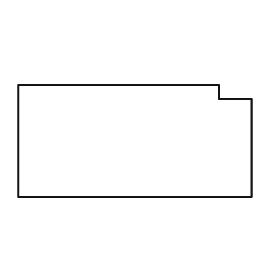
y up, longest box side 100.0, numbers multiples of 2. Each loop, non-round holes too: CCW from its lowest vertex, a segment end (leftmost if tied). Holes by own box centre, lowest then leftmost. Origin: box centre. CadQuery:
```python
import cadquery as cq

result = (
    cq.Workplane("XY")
    .moveTo(-50.0, -24.0)
    .lineTo(50.0, -24.0)
    .lineTo(50.0, 18.0)
    .lineTo(36.0, 18.0)
    .lineTo(36.0, 24.0)
    .lineTo(-50.0, 24.0)
    .close()
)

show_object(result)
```